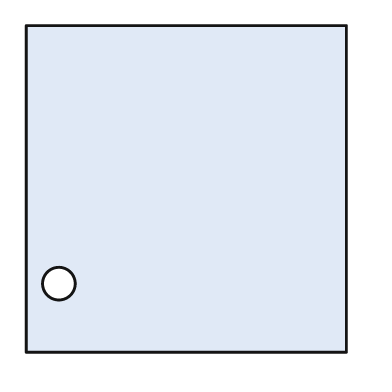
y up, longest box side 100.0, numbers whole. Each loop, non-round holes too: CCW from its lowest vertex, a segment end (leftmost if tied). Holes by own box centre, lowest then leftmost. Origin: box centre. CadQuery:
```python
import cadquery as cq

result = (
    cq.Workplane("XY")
    .moveTo(-49.0, -50.0)
    .lineTo(49.0, -50.0)
    .lineTo(49.0, 50.0)
    .lineTo(-49.0, 50.0)
    .close()
    .moveTo(-39.0, -29.0)
    .circle(5.0)
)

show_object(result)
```